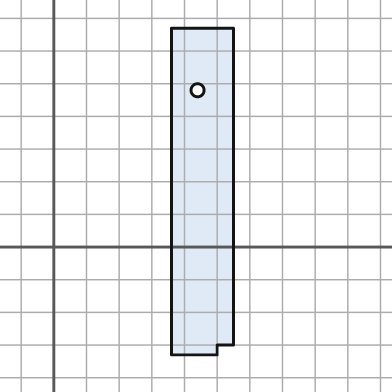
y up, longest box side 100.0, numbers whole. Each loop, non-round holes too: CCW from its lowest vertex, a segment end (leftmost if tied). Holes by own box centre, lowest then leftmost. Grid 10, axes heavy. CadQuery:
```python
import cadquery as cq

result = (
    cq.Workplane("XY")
    .moveTo(36.0, -33.0)
    .lineTo(50.0, -33.0)
    .lineTo(50.0, -30.0)
    .lineTo(55.0, -30.0)
    .lineTo(55.0, 67.0)
    .lineTo(36.0, 67.0)
    .close()
    .moveTo(44.0, 48.0)
    .circle(2.0)
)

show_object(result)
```